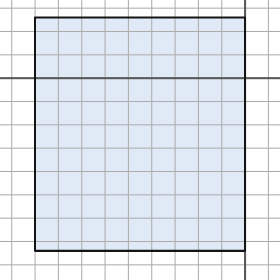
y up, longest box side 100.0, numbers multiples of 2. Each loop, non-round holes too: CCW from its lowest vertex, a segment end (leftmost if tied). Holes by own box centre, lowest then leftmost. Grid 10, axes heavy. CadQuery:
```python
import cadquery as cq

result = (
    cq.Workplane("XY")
    .moveTo(-90.0, -74.0)
    .lineTo(0.0, -74.0)
    .lineTo(0.0, 26.0)
    .lineTo(-90.0, 26.0)
    .close()
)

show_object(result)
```